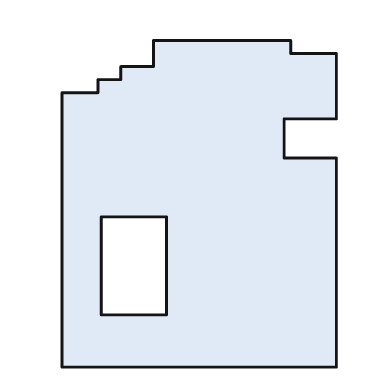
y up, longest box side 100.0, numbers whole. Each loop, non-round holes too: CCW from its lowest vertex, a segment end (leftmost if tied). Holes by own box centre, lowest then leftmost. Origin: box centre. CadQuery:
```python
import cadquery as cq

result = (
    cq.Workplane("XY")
    .moveTo(-42.0, -50.0)
    .lineTo(42.0, -50.0)
    .lineTo(42.0, 14.0)
    .lineTo(26.0, 14.0)
    .lineTo(26.0, 26.0)
    .lineTo(42.0, 26.0)
    .lineTo(42.0, 46.0)
    .lineTo(28.0, 46.0)
    .lineTo(28.0, 50.0)
    .lineTo(-14.0, 50.0)
    .lineTo(-14.0, 42.0)
    .lineTo(-24.0, 42.0)
    .lineTo(-24.0, 38.0)
    .lineTo(-31.0, 38.0)
    .lineTo(-31.0, 34.0)
    .lineTo(-42.0, 34.0)
    .close()
    .moveTo(-30.0, -34.0)
    .lineTo(-10.0, -34.0)
    .lineTo(-10.0, -4.0)
    .lineTo(-30.0, -4.0)
    .close()
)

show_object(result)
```